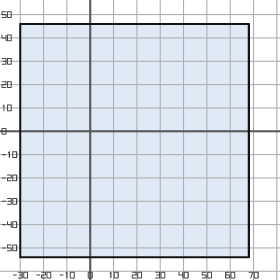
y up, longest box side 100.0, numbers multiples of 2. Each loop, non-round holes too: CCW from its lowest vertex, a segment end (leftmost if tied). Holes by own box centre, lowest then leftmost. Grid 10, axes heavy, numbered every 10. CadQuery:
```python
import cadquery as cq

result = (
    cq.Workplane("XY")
    .moveTo(-30.0, -54.0)
    .lineTo(68.0, -54.0)
    .lineTo(68.0, 46.0)
    .lineTo(-30.0, 46.0)
    .close()
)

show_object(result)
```